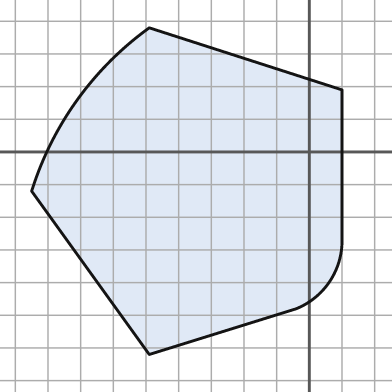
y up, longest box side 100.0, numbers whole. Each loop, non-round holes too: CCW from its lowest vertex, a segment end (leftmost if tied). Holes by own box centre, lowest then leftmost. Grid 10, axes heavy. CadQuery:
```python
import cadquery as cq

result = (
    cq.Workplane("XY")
    .moveTo(-49.0, -62.0)
    .lineTo(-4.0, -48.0)
    .threePointArc((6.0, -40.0), (10.0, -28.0))
    .lineTo(10.0, 19.0)
    .lineTo(-49.0, 38.0)
    .threePointArc((-71.0, 16.0), (-85.0, -12.0))
    .close()
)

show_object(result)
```